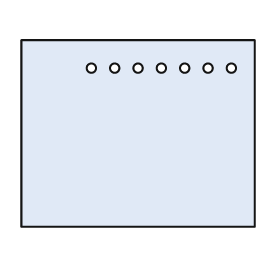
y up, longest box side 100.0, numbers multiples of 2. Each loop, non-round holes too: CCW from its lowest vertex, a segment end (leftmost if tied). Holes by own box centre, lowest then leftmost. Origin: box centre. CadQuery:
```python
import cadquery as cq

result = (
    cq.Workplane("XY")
    .moveTo(-50.0, -40.0)
    .lineTo(50.0, -40.0)
    .lineTo(50.0, 40.0)
    .lineTo(-50.0, 40.0)
    .close()
    .moveTo(-20.0, 28.0)
    .circle(2.0)
    .moveTo(-10.0, 28.0)
    .circle(2.0)
    .moveTo(0.0, 28.0)
    .circle(2.0)
    .moveTo(10.0, 28.0)
    .circle(2.0)
    .moveTo(20.0, 28.0)
    .circle(2.0)
    .moveTo(30.0, 28.0)
    .circle(2.0)
    .moveTo(40.0, 28.0)
    .circle(2.0)
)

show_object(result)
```